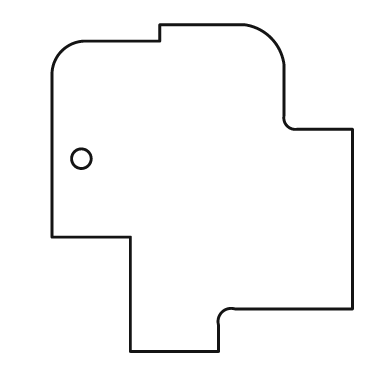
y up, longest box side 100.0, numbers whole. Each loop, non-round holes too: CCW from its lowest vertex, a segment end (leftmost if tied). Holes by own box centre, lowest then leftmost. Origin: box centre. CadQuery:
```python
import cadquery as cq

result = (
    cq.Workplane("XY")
    .moveTo(-22.0, -50.0)
    .lineTo(5.0, -50.0)
    .lineTo(5.0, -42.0)
    .threePointArc((6.0, -38.0), (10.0, -37.0))
    .lineTo(46.0, -37.0)
    .lineTo(46.0, 18.0)
    .lineTo(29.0, 18.0)
    .threePointArc((26.0, 19.0), (25.0, 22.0))
    .lineTo(25.0, 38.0)
    .threePointArc((21.0, 46.0), (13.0, 50.0))
    .lineTo(-13.0, 50.0)
    .lineTo(-13.0, 45.0)
    .lineTo(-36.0, 45.0)
    .threePointArc((-43.0, 42.0), (-46.0, 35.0))
    .lineTo(-46.0, -15.0)
    .lineTo(-22.0, -15.0)
    .close()
    .moveTo(-37.0, 9.0)
    .circle(3.0)
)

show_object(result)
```